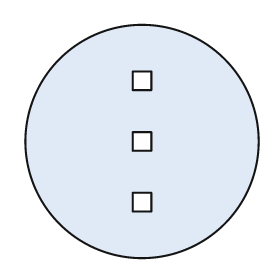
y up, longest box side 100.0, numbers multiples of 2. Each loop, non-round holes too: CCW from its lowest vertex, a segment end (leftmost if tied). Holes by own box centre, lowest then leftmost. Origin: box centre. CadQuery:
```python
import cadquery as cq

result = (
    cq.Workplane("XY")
    .moveTo(0.0, 0.0)
    .circle(50.0)
    .moveTo(-4.0, -30.0)
    .lineTo(4.0, -30.0)
    .lineTo(4.0, -22.0)
    .lineTo(-4.0, -22.0)
    .close()
    .moveTo(-4.0, -4.0)
    .lineTo(4.0, -4.0)
    .lineTo(4.0, 4.0)
    .lineTo(-4.0, 4.0)
    .close()
    .moveTo(-4.0, 22.0)
    .lineTo(4.0, 22.0)
    .lineTo(4.0, 30.0)
    .lineTo(-4.0, 30.0)
    .close()
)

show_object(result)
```